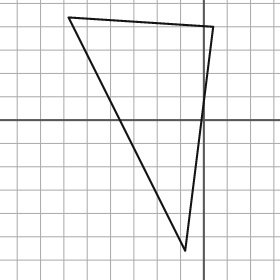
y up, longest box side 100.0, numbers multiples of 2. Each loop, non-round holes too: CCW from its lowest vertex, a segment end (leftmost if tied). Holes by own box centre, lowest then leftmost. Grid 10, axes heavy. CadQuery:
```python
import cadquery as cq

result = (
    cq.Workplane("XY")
    .moveTo(-8.0, -56.0)
    .lineTo(4.0, 40.0)
    .lineTo(-58.0, 44.0)
    .close()
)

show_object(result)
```